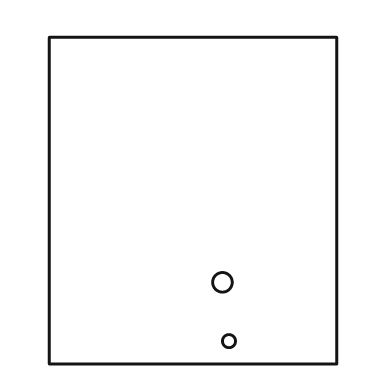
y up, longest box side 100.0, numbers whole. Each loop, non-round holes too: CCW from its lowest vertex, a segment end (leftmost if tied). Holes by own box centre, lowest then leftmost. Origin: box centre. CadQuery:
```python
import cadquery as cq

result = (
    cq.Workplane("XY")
    .moveTo(-44.0, -50.0)
    .lineTo(44.0, -50.0)
    .lineTo(44.0, 50.0)
    .lineTo(-44.0, 50.0)
    .close()
    .moveTo(11.0, -43.0)
    .circle(2.0)
    .moveTo(9.0, -25.0)
    .circle(3.0)
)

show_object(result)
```